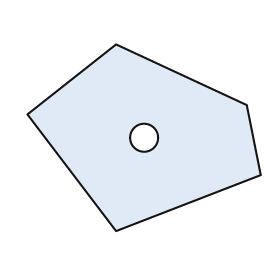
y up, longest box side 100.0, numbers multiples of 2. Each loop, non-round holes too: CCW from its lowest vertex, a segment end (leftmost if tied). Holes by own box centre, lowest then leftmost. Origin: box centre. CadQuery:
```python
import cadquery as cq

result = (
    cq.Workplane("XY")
    .moveTo(-12.0, -40.0)
    .lineTo(50.0, -16.0)
    .lineTo(44.0, 14.0)
    .lineTo(-12.0, 40.0)
    .lineTo(-50.0, 10.0)
    .close()
    .moveTo(0.0, 0.0)
    .circle(6.0)
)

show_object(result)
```